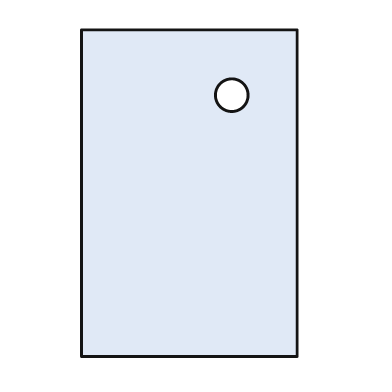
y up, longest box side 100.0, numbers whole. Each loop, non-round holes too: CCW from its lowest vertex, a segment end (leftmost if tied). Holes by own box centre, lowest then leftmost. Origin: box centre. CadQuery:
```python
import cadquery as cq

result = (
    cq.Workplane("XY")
    .moveTo(-33.0, -50.0)
    .lineTo(33.0, -50.0)
    .lineTo(33.0, 50.0)
    .lineTo(-33.0, 50.0)
    .close()
    .moveTo(13.0, 30.0)
    .circle(5.0)
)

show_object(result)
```